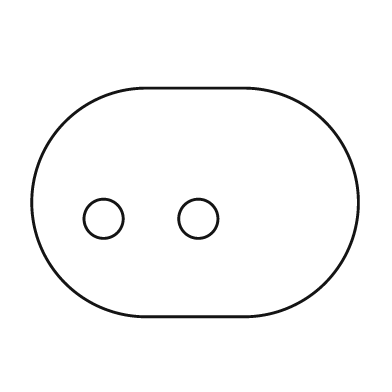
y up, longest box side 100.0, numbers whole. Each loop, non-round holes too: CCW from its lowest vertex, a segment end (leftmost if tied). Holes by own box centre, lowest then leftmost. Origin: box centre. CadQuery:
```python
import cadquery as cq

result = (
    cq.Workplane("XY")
    .moveTo(-15.0, -35.0)
    .lineTo(15.0, -35.0)
    .threePointArc((50.0, 0.0), (15.0, 35.0))
    .lineTo(-15.0, 35.0)
    .threePointArc((-50.0, 0.0), (-15.0, -35.0))
    .close()
    .moveTo(-28.0, -5.0)
    .circle(6.0)
    .moveTo(1.0, -5.0)
    .circle(6.0)
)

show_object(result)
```